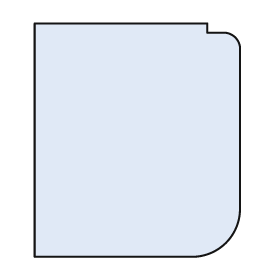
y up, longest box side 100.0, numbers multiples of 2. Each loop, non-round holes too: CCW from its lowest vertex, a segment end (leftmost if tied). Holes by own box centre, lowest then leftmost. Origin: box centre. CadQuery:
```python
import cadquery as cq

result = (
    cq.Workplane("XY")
    .moveTo(-44.0, -50.0)
    .lineTo(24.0, -50.0)
    .threePointArc((38.0, -44.0), (44.0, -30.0))
    .lineTo(44.0, 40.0)
    .threePointArc((42.0, 44.0), (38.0, 46.0))
    .lineTo(30.0, 46.0)
    .lineTo(30.0, 50.0)
    .lineTo(-44.0, 50.0)
    .close()
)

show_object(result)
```